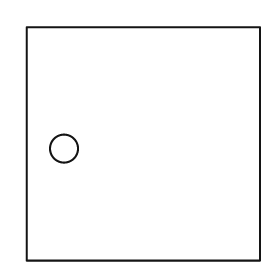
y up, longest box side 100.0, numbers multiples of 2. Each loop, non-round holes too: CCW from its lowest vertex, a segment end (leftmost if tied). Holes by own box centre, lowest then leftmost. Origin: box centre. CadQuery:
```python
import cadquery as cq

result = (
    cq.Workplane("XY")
    .moveTo(-50.0, -50.0)
    .lineTo(50.0, -50.0)
    .lineTo(50.0, 50.0)
    .lineTo(-50.0, 50.0)
    .close()
    .moveTo(-34.0, -2.0)
    .circle(6.0)
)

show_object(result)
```